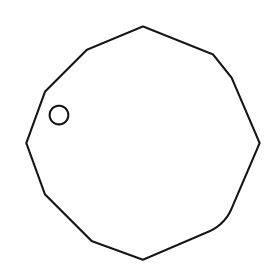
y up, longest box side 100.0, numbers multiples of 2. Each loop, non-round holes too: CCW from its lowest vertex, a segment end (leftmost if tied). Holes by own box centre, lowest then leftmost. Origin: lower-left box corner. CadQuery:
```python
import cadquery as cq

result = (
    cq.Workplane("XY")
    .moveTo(50.0, 0.0)
    .lineTo(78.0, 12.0)
    .threePointArc((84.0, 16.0), (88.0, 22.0))
    .lineTo(100.0, 50.0)
    .lineTo(88.0, 78.0)
    .lineTo(80.0, 88.0)
    .lineTo(50.0, 100.0)
    .lineTo(26.0, 90.0)
    .lineTo(8.0, 72.0)
    .lineTo(0.0, 50.0)
    .lineTo(8.0, 28.0)
    .lineTo(28.0, 8.0)
    .close()
    .moveTo(14.0, 62.0)
    .circle(4.0)
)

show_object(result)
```